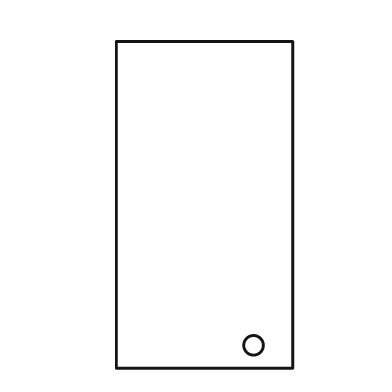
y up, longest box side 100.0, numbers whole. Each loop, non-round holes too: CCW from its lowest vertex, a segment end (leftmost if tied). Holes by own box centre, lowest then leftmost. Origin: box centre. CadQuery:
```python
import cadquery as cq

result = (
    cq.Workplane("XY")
    .moveTo(-27.0, -50.0)
    .lineTo(27.0, -50.0)
    .lineTo(27.0, 50.0)
    .lineTo(-27.0, 50.0)
    .close()
    .moveTo(15.0, -43.0)
    .circle(3.0)
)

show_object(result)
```